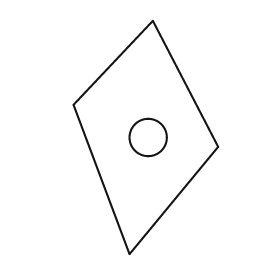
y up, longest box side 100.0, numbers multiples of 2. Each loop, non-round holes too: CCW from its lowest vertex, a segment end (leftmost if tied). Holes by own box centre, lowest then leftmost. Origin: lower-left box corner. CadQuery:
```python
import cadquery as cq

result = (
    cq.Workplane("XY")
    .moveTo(24.0, 0.0)
    .lineTo(62.0, 46.0)
    .lineTo(34.0, 100.0)
    .lineTo(0.0, 64.0)
    .close()
    .moveTo(32.0, 50.0)
    .circle(8.0)
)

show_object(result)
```